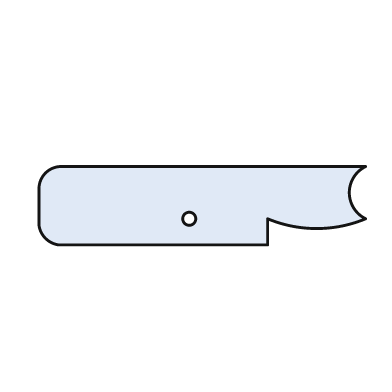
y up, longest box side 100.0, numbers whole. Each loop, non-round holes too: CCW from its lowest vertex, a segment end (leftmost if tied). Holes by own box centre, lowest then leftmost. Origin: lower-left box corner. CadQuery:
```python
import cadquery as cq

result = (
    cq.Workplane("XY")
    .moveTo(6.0, 0.0)
    .lineTo(70.0, 0.0)
    .lineTo(70.0, 8.0)
    .threePointArc((85.0, 5.0), (100.0, 8.0))
    .threePointArc((95.0, 16.0), (100.0, 24.0))
    .lineTo(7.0, 24.0)
    .threePointArc((2.0, 22.0), (0.0, 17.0))
    .lineTo(0.0, 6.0)
    .threePointArc((2.0, 2.0), (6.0, 0.0))
    .close()
    .moveTo(46.0, 8.0)
    .circle(2.0)
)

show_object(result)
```